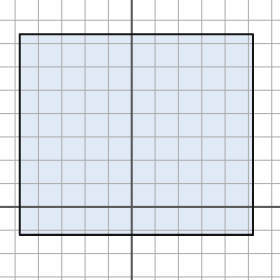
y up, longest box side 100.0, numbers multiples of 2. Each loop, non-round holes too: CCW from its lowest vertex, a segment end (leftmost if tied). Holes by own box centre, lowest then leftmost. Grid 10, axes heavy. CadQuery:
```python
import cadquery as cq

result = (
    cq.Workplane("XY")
    .moveTo(-48.0, -12.0)
    .lineTo(52.0, -12.0)
    .lineTo(52.0, 74.0)
    .lineTo(-48.0, 74.0)
    .close()
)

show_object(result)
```